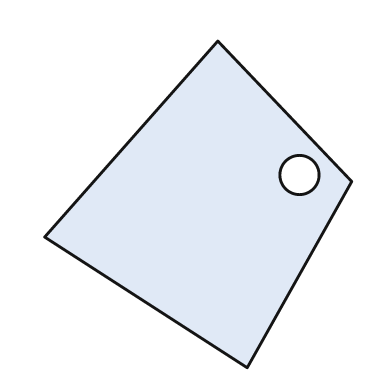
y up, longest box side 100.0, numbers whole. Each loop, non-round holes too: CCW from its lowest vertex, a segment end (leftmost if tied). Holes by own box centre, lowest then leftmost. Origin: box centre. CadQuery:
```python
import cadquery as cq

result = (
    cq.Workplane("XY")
    .moveTo(15.0, -50.0)
    .lineTo(47.0, 7.0)
    .lineTo(6.0, 50.0)
    .lineTo(-47.0, -10.0)
    .close()
    .moveTo(31.0, 9.0)
    .circle(6.0)
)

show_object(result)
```